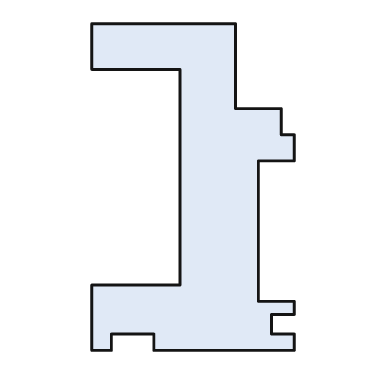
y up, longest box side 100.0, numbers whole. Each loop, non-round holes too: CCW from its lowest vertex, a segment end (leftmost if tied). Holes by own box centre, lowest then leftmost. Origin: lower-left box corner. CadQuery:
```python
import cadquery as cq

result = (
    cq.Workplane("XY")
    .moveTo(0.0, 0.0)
    .lineTo(6.0, 0.0)
    .lineTo(6.0, 5.0)
    .lineTo(19.0, 5.0)
    .lineTo(19.0, 0.0)
    .lineTo(62.0, 0.0)
    .lineTo(62.0, 5.0)
    .lineTo(55.0, 5.0)
    .lineTo(55.0, 11.0)
    .lineTo(62.0, 11.0)
    .lineTo(62.0, 15.0)
    .lineTo(51.0, 15.0)
    .lineTo(51.0, 58.0)
    .lineTo(62.0, 58.0)
    .lineTo(62.0, 66.0)
    .lineTo(58.0, 66.0)
    .lineTo(58.0, 74.0)
    .lineTo(44.0, 74.0)
    .lineTo(44.0, 100.0)
    .lineTo(0.0, 100.0)
    .lineTo(0.0, 86.0)
    .lineTo(27.0, 86.0)
    .lineTo(27.0, 20.0)
    .lineTo(0.0, 20.0)
    .close()
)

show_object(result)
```